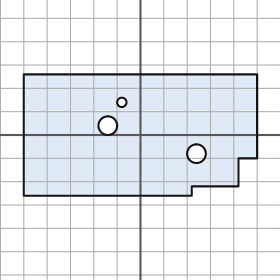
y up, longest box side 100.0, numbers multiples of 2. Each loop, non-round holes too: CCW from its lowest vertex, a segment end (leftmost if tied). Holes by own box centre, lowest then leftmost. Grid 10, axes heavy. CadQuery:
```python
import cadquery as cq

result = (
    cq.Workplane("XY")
    .moveTo(-50.0, -26.0)
    .lineTo(22.0, -26.0)
    .lineTo(22.0, -22.0)
    .lineTo(42.0, -22.0)
    .lineTo(42.0, -10.0)
    .lineTo(50.0, -10.0)
    .lineTo(50.0, 26.0)
    .lineTo(-50.0, 26.0)
    .close()
    .moveTo(24.0, -8.0)
    .circle(4.0)
    .moveTo(-14.0, 4.0)
    .circle(4.0)
    .moveTo(-8.0, 14.0)
    .circle(2.0)
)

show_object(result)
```